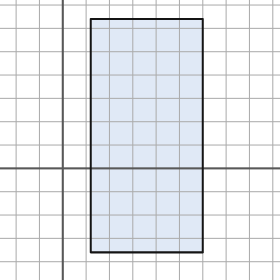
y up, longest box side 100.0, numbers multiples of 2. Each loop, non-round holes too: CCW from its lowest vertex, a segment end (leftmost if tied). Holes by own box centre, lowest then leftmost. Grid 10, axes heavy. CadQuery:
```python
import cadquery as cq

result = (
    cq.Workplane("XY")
    .moveTo(12.0, -36.0)
    .lineTo(60.0, -36.0)
    .lineTo(60.0, 64.0)
    .lineTo(12.0, 64.0)
    .close()
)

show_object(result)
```